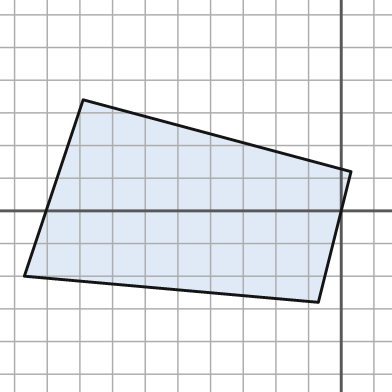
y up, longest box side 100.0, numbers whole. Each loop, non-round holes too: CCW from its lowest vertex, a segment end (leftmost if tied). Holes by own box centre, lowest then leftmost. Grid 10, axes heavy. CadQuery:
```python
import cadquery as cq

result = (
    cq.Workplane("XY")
    .moveTo(-7.0, -28.0)
    .lineTo(3.0, 12.0)
    .lineTo(-79.0, 34.0)
    .lineTo(-97.0, -20.0)
    .close()
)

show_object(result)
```